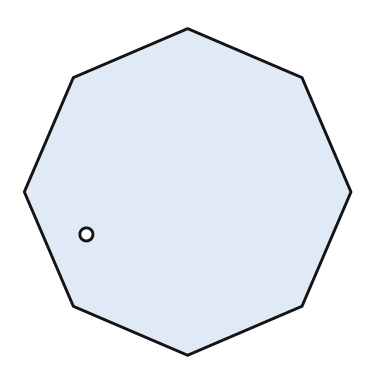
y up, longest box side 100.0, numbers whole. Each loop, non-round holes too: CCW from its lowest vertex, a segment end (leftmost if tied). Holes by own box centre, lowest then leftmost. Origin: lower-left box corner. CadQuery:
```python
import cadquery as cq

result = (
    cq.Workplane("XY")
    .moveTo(50.0, 0.0)
    .lineTo(85.0, 15.0)
    .lineTo(100.0, 50.0)
    .lineTo(85.0, 85.0)
    .lineTo(50.0, 100.0)
    .lineTo(15.0, 85.0)
    .lineTo(0.0, 50.0)
    .lineTo(15.0, 15.0)
    .close()
    .moveTo(19.0, 37.0)
    .circle(2.0)
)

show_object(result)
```